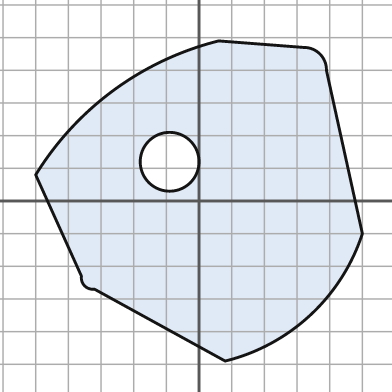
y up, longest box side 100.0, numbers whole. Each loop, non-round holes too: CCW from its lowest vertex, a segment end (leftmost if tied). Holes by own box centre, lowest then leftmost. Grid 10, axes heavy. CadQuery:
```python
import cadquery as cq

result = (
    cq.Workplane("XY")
    .moveTo(8.0, -49.0)
    .threePointArc((34.0, -35.0), (50.0, -10.0))
    .lineTo(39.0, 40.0)
    .threePointArc((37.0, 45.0), (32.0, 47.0))
    .lineTo(6.0, 49.0)
    .threePointArc((-26.0, 34.0), (-50.0, 8.0))
    .lineTo(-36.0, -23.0)
    .threePointArc((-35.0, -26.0), (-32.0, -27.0))
    .close()
    .moveTo(-9.0, 12.0)
    .circle(9.0)
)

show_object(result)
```